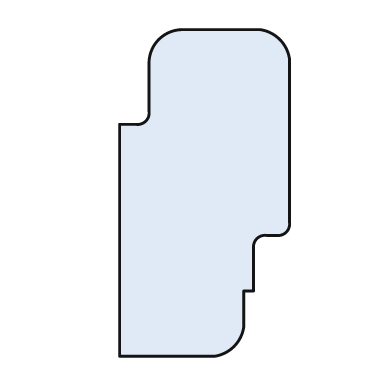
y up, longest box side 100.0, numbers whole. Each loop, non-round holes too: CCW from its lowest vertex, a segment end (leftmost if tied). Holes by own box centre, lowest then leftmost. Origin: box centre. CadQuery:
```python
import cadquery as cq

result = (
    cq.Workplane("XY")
    .moveTo(-26.0, -50.0)
    .lineTo(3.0, -50.0)
    .threePointArc((9.0, -47.0), (12.0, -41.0))
    .lineTo(12.0, -30.0)
    .lineTo(15.0, -30.0)
    .lineTo(15.0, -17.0)
    .threePointArc((16.0, -14.0), (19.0, -13.0))
    .lineTo(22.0, -13.0)
    .threePointArc((25.0, -12.0), (26.0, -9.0))
    .lineTo(26.0, 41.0)
    .threePointArc((23.0, 47.0), (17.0, 50.0))
    .lineTo(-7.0, 50.0)
    .threePointArc((-14.0, 47.0), (-17.0, 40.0))
    .lineTo(-17.0, 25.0)
    .threePointArc((-18.0, 22.0), (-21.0, 21.0))
    .lineTo(-26.0, 21.0)
    .close()
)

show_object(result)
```